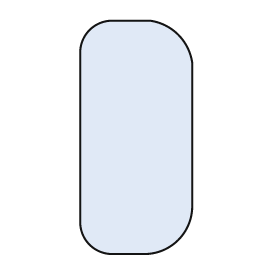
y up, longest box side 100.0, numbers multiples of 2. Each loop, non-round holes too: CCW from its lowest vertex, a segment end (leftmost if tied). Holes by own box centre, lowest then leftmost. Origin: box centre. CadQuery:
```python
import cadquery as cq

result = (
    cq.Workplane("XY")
    .moveTo(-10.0, -50.0)
    .lineTo(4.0, -50.0)
    .threePointArc((18.0, -44.0), (24.0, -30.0))
    .lineTo(24.0, 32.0)
    .threePointArc((18.0, 44.0), (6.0, 50.0))
    .lineTo(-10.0, 50.0)
    .threePointArc((-20.0, 46.0), (-24.0, 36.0))
    .lineTo(-24.0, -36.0)
    .threePointArc((-20.0, -46.0), (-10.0, -50.0))
    .close()
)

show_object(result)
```